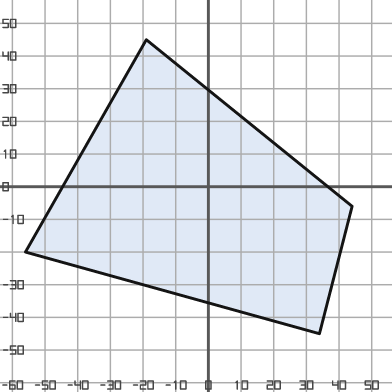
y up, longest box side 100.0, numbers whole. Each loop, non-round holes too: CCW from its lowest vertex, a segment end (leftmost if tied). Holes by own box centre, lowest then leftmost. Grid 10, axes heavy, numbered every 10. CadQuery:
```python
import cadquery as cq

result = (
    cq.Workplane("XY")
    .moveTo(34.0, -45.0)
    .lineTo(44.0, -6.0)
    .lineTo(-19.0, 45.0)
    .lineTo(-56.0, -20.0)
    .close()
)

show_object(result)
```